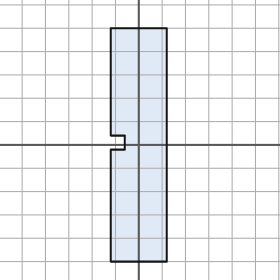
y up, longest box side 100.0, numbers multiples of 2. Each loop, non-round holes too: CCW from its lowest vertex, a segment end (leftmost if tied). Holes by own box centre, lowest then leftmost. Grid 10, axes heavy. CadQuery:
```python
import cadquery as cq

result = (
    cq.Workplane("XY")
    .moveTo(-12.0, -50.0)
    .lineTo(12.0, -50.0)
    .lineTo(12.0, 50.0)
    .lineTo(-12.0, 50.0)
    .lineTo(-12.0, 4.0)
    .lineTo(-6.0, 4.0)
    .lineTo(-6.0, -2.0)
    .lineTo(-12.0, -2.0)
    .close()
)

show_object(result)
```